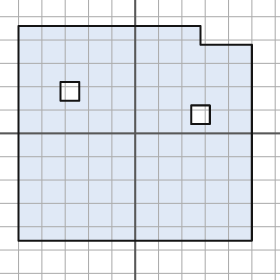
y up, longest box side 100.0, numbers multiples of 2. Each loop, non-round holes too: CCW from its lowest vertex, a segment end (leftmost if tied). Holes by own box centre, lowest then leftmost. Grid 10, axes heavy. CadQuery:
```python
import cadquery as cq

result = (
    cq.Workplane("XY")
    .moveTo(-50.0, -46.0)
    .lineTo(50.0, -46.0)
    .lineTo(50.0, 38.0)
    .lineTo(28.0, 38.0)
    .lineTo(28.0, 46.0)
    .lineTo(-50.0, 46.0)
    .close()
    .moveTo(24.0, 4.0)
    .lineTo(32.0, 4.0)
    .lineTo(32.0, 12.0)
    .lineTo(24.0, 12.0)
    .close()
    .moveTo(-32.0, 14.0)
    .lineTo(-24.0, 14.0)
    .lineTo(-24.0, 22.0)
    .lineTo(-32.0, 22.0)
    .close()
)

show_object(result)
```